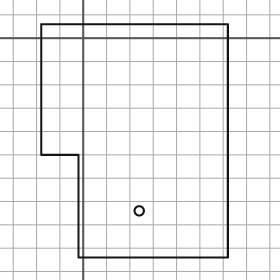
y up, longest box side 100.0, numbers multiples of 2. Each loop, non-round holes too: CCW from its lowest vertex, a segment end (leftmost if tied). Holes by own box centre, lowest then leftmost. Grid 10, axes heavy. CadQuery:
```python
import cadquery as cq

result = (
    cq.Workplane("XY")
    .moveTo(-2.0, -94.0)
    .lineTo(62.0, -94.0)
    .lineTo(62.0, 6.0)
    .lineTo(-18.0, 6.0)
    .lineTo(-18.0, -50.0)
    .lineTo(-2.0, -50.0)
    .close()
    .moveTo(24.0, -74.0)
    .circle(2.0)
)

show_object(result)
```